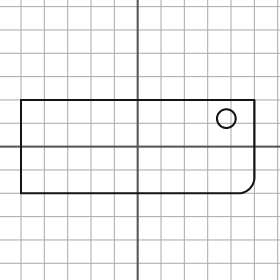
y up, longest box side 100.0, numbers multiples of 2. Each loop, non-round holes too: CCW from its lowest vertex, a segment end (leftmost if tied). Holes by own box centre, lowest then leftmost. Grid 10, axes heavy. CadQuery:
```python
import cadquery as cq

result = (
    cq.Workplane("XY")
    .moveTo(-50.0, -20.0)
    .lineTo(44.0, -20.0)
    .threePointArc((48.0, -18.0), (50.0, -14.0))
    .lineTo(50.0, 20.0)
    .lineTo(-50.0, 20.0)
    .close()
    .moveTo(38.0, 12.0)
    .circle(4.0)
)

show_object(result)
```